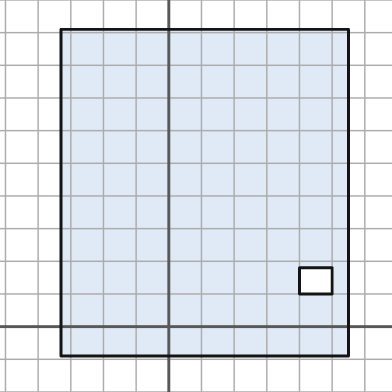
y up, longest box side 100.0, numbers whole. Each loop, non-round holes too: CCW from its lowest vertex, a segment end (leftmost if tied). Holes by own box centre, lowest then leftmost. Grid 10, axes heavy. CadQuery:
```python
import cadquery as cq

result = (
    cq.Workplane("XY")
    .moveTo(-33.0, -9.0)
    .lineTo(55.0, -9.0)
    .lineTo(55.0, 91.0)
    .lineTo(-33.0, 91.0)
    .close()
    .moveTo(40.0, 10.0)
    .lineTo(50.0, 10.0)
    .lineTo(50.0, 18.0)
    .lineTo(40.0, 18.0)
    .close()
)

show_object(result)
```